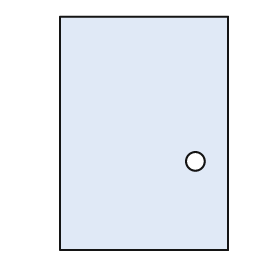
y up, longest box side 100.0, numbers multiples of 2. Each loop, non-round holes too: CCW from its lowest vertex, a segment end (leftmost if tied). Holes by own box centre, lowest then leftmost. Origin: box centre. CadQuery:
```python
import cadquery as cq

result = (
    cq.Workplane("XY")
    .moveTo(-36.0, -50.0)
    .lineTo(36.0, -50.0)
    .lineTo(36.0, 50.0)
    .lineTo(-36.0, 50.0)
    .close()
    .moveTo(22.0, -12.0)
    .circle(4.0)
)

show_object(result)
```